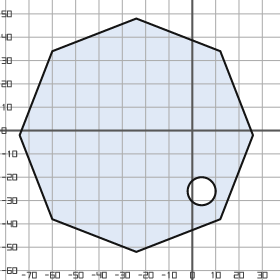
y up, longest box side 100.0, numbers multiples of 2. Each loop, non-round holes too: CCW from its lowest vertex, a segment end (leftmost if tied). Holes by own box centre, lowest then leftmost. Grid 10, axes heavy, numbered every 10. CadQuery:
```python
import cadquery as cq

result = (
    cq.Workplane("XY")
    .moveTo(-24.0, -52.0)
    .lineTo(12.0, -38.0)
    .lineTo(26.0, -2.0)
    .lineTo(12.0, 34.0)
    .lineTo(-24.0, 48.0)
    .lineTo(-60.0, 34.0)
    .lineTo(-74.0, -2.0)
    .lineTo(-60.0, -38.0)
    .close()
    .moveTo(4.0, -26.0)
    .circle(6.0)
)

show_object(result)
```